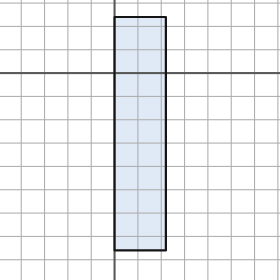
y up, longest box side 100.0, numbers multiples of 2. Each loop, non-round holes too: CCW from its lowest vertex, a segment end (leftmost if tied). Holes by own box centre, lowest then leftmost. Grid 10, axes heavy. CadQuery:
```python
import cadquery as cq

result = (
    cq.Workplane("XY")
    .moveTo(0.0, -76.0)
    .lineTo(22.0, -76.0)
    .lineTo(22.0, 24.0)
    .lineTo(0.0, 24.0)
    .close()
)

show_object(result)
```